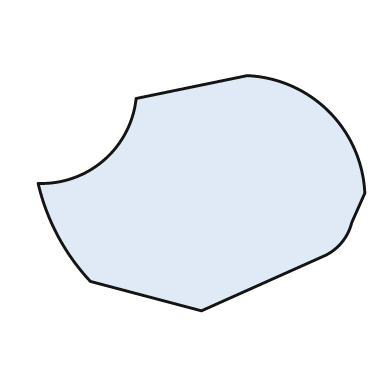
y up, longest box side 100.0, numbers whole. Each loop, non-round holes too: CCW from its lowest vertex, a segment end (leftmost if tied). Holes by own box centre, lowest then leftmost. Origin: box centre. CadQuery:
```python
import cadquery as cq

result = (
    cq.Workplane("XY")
    .moveTo(0.0, -36.0)
    .lineTo(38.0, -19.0)
    .threePointArc((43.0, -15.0), (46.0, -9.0))
    .lineTo(50.0, 0.0)
    .threePointArc((39.0, 25.0), (14.0, 36.0))
    .lineTo(-20.0, 29.0)
    .threePointArc((-30.0, 10.0), (-50.0, 3.0))
    .threePointArc((-44.0, -13.0), (-34.0, -27.0))
    .close()
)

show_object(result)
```